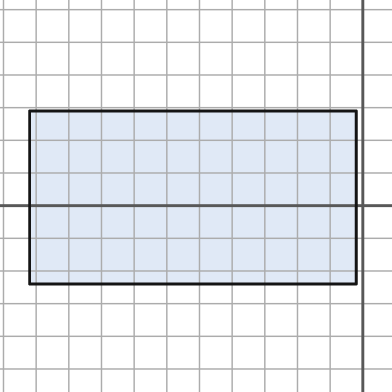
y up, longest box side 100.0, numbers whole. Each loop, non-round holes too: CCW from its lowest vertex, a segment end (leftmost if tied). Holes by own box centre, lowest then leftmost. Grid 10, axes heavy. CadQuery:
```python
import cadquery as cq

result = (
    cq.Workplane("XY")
    .moveTo(-102.0, -24.0)
    .lineTo(-2.0, -24.0)
    .lineTo(-2.0, 29.0)
    .lineTo(-102.0, 29.0)
    .close()
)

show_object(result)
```